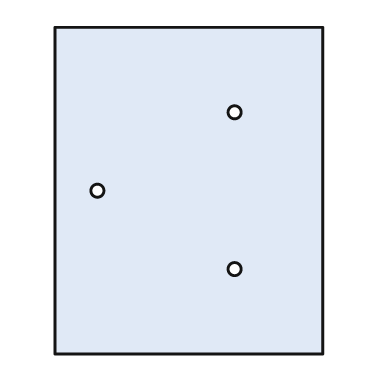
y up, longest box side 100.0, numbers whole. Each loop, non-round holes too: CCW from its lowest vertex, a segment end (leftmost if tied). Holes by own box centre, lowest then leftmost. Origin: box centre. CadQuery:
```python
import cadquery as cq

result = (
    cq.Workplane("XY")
    .moveTo(-41.0, -50.0)
    .lineTo(41.0, -50.0)
    .lineTo(41.0, 50.0)
    .lineTo(-41.0, 50.0)
    .close()
    .moveTo(14.0, -24.0)
    .circle(2.0)
    .moveTo(-28.0, 0.0)
    .circle(2.0)
    .moveTo(14.0, 24.0)
    .circle(2.0)
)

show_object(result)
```